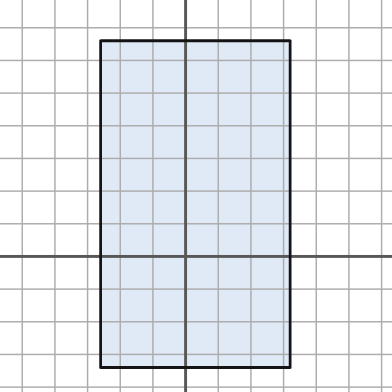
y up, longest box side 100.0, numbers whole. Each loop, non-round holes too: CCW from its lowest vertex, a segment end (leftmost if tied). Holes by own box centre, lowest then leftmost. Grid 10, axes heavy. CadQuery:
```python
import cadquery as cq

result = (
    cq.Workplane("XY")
    .moveTo(-26.0, -34.0)
    .lineTo(32.0, -34.0)
    .lineTo(32.0, 66.0)
    .lineTo(-26.0, 66.0)
    .close()
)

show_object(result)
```